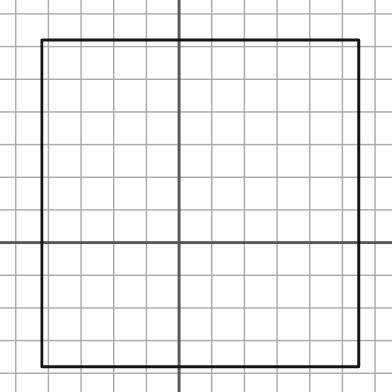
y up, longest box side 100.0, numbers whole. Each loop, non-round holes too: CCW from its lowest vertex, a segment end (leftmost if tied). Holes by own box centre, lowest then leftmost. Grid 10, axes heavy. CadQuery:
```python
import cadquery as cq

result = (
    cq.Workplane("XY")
    .moveTo(-42.0, -38.0)
    .lineTo(55.0, -38.0)
    .lineTo(55.0, 62.0)
    .lineTo(-42.0, 62.0)
    .close()
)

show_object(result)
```